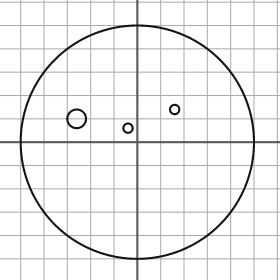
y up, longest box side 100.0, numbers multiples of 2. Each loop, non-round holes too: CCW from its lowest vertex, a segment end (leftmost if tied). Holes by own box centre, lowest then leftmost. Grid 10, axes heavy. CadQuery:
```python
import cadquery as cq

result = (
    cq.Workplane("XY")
    .moveTo(0.0, 0.0)
    .circle(50.0)
    .moveTo(-4.0, 6.0)
    .circle(2.0)
    .moveTo(-26.0, 10.0)
    .circle(4.0)
    .moveTo(16.0, 14.0)
    .circle(2.0)
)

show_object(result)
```